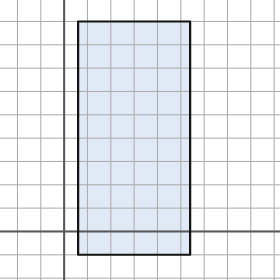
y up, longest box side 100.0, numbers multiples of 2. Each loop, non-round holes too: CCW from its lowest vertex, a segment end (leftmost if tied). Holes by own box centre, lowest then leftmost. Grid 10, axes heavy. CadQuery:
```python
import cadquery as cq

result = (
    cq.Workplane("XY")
    .moveTo(6.0, -10.0)
    .lineTo(54.0, -10.0)
    .lineTo(54.0, 90.0)
    .lineTo(6.0, 90.0)
    .close()
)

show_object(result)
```